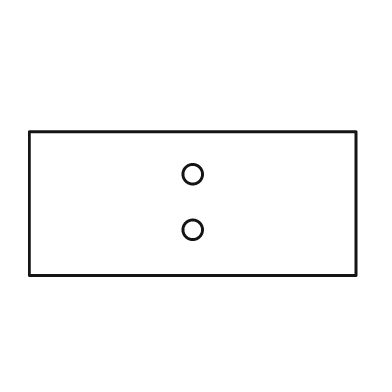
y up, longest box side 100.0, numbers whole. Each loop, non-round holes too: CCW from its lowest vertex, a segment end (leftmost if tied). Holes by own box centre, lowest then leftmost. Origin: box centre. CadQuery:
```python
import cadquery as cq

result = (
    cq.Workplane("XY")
    .moveTo(-50.0, -22.0)
    .lineTo(50.0, -22.0)
    .lineTo(50.0, 22.0)
    .lineTo(-50.0, 22.0)
    .close()
    .moveTo(0.0, -8.0)
    .circle(3.0)
    .moveTo(0.0, 9.0)
    .circle(3.0)
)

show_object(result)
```